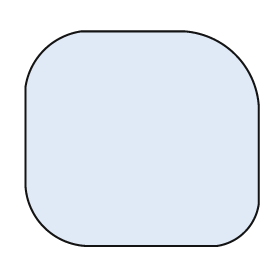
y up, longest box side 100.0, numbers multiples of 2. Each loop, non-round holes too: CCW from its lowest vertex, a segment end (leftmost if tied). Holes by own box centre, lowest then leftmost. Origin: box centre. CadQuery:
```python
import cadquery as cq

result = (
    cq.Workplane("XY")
    .moveTo(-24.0, -46.0)
    .lineTo(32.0, -46.0)
    .threePointArc((44.0, -40.0), (50.0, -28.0))
    .lineTo(50.0, 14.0)
    .threePointArc((40.0, 36.0), (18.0, 46.0))
    .lineTo(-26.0, 46.0)
    .threePointArc((-42.0, 38.0), (-50.0, 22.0))
    .lineTo(-50.0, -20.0)
    .threePointArc((-42.0, -38.0), (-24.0, -46.0))
    .close()
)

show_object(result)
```